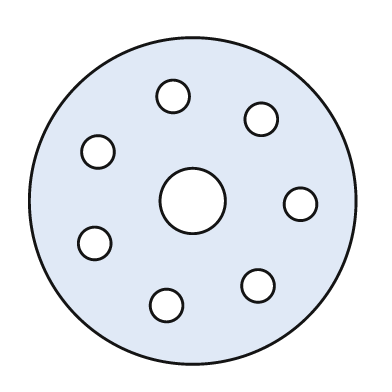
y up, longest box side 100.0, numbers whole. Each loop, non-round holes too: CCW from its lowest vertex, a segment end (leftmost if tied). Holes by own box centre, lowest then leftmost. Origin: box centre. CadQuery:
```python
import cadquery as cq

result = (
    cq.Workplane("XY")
    .moveTo(0.0, 0.0)
    .circle(50.0)
    .moveTo(-8.0, -32.0)
    .circle(5.0)
    .moveTo(20.0, -26.0)
    .circle(5.0)
    .moveTo(-30.0, -13.0)
    .circle(5.0)
    .moveTo(33.0, -1.0)
    .circle(5.0)
    .moveTo(0.0, 0.0)
    .circle(10.0)
    .moveTo(-29.0, 15.0)
    .circle(5.0)
    .moveTo(21.0, 25.0)
    .circle(5.0)
    .moveTo(-6.0, 32.0)
    .circle(5.0)
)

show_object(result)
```